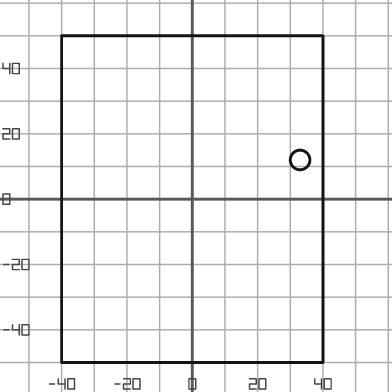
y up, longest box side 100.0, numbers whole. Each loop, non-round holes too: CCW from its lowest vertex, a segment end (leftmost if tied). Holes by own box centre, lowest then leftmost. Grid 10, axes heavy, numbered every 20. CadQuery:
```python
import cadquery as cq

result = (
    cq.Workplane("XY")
    .moveTo(-40.0, -50.0)
    .lineTo(40.0, -50.0)
    .lineTo(40.0, 50.0)
    .lineTo(-40.0, 50.0)
    .close()
    .moveTo(33.0, 12.0)
    .circle(3.0)
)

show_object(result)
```